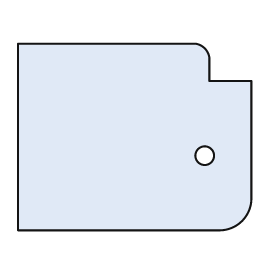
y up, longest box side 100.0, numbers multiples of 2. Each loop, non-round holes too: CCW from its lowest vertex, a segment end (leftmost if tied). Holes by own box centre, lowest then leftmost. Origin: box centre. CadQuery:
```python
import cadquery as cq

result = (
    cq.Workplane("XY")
    .moveTo(-50.0, -40.0)
    .lineTo(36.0, -40.0)
    .threePointArc((46.0, -36.0), (50.0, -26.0))
    .lineTo(50.0, 24.0)
    .lineTo(32.0, 24.0)
    .lineTo(32.0, 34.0)
    .threePointArc((30.0, 38.0), (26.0, 40.0))
    .lineTo(-50.0, 40.0)
    .close()
    .moveTo(30.0, -8.0)
    .circle(4.0)
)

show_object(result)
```